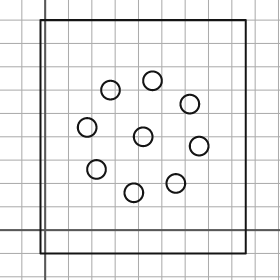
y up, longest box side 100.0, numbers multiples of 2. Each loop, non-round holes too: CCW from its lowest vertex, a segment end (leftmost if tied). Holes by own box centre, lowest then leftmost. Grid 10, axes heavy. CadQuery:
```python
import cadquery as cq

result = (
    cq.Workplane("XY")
    .moveTo(-2.0, -10.0)
    .lineTo(86.0, -10.0)
    .lineTo(86.0, 90.0)
    .lineTo(-2.0, 90.0)
    .close()
    .moveTo(38.0, 16.0)
    .circle(4.0)
    .moveTo(56.0, 20.0)
    .circle(4.0)
    .moveTo(22.0, 26.0)
    .circle(4.0)
    .moveTo(66.0, 36.0)
    .circle(4.0)
    .moveTo(42.0, 40.0)
    .circle(4.0)
    .moveTo(18.0, 44.0)
    .circle(4.0)
    .moveTo(62.0, 54.0)
    .circle(4.0)
    .moveTo(28.0, 60.0)
    .circle(4.0)
    .moveTo(46.0, 64.0)
    .circle(4.0)
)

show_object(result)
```